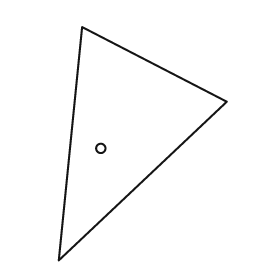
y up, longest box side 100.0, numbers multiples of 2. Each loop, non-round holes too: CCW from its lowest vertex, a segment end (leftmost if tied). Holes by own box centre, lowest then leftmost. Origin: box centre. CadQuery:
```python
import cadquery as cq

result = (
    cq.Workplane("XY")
    .moveTo(-36.0, -50.0)
    .lineTo(36.0, 18.0)
    .lineTo(-26.0, 50.0)
    .close()
    .moveTo(-18.0, -2.0)
    .circle(2.0)
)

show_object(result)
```